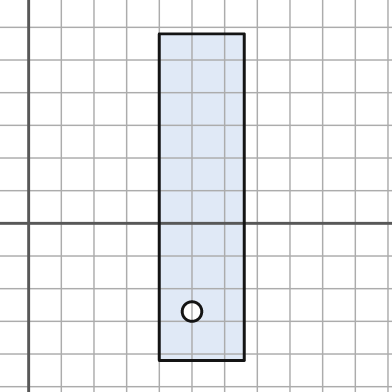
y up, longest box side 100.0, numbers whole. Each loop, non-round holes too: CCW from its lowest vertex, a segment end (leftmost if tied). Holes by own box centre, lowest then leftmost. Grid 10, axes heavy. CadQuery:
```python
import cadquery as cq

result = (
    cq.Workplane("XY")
    .moveTo(40.0, -42.0)
    .lineTo(66.0, -42.0)
    .lineTo(66.0, 58.0)
    .lineTo(40.0, 58.0)
    .close()
    .moveTo(50.0, -27.0)
    .circle(3.0)
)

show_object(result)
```